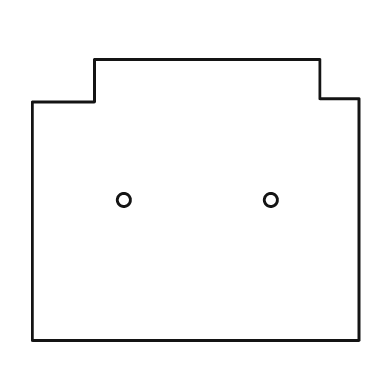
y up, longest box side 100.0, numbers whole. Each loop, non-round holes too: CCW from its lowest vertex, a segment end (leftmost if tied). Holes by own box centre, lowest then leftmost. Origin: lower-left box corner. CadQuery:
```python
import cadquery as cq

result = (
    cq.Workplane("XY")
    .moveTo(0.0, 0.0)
    .lineTo(100.0, 0.0)
    .lineTo(100.0, 74.0)
    .lineTo(88.0, 74.0)
    .lineTo(88.0, 86.0)
    .lineTo(19.0, 86.0)
    .lineTo(19.0, 73.0)
    .lineTo(0.0, 73.0)
    .close()
    .moveTo(28.0, 43.0)
    .circle(2.0)
    .moveTo(73.0, 43.0)
    .circle(2.0)
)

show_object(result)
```